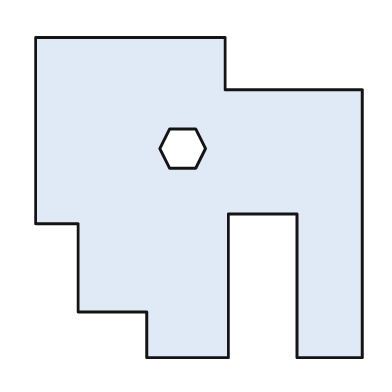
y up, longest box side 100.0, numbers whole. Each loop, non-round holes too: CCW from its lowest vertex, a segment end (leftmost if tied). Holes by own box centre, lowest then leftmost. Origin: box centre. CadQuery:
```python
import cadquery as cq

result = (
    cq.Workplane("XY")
    .moveTo(-16.0, -49.0)
    .lineTo(9.0, -49.0)
    .lineTo(9.0, -5.0)
    .lineTo(30.0, -5.0)
    .lineTo(30.0, -49.0)
    .lineTo(50.0, -49.0)
    .lineTo(50.0, 33.0)
    .lineTo(8.0, 33.0)
    .lineTo(8.0, 49.0)
    .lineTo(-50.0, 49.0)
    .lineTo(-50.0, -8.0)
    .lineTo(-37.0, -8.0)
    .lineTo(-37.0, -35.0)
    .lineTo(-16.0, -35.0)
    .close()
    .moveTo(-9.0, 9.0)
    .lineTo(-1.0, 9.0)
    .lineTo(2.0, 15.0)
    .lineTo(-1.0, 21.0)
    .lineTo(-9.0, 21.0)
    .lineTo(-12.0, 15.0)
    .close()
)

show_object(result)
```